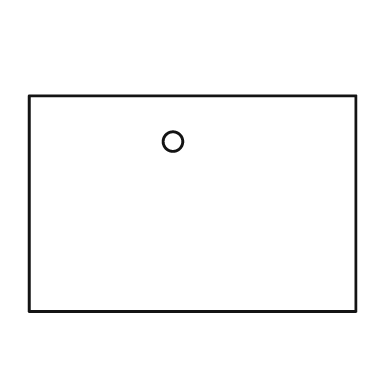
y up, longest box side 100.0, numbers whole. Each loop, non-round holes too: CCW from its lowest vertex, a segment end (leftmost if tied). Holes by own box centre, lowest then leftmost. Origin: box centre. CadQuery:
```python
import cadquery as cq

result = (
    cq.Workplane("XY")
    .moveTo(-50.0, -33.0)
    .lineTo(50.0, -33.0)
    .lineTo(50.0, 33.0)
    .lineTo(-50.0, 33.0)
    .close()
    .moveTo(-6.0, 19.0)
    .circle(3.0)
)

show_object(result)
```